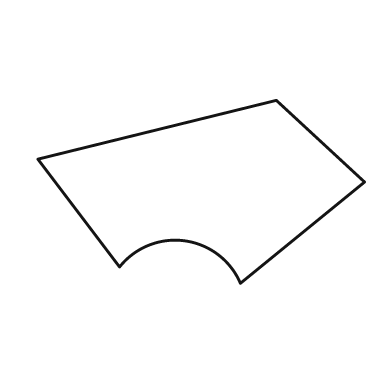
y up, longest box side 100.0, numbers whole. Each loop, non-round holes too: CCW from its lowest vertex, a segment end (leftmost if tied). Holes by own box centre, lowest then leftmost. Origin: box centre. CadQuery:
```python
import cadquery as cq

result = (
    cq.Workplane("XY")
    .moveTo(12.0, -28.0)
    .lineTo(50.0, 3.0)
    .lineTo(23.0, 28.0)
    .lineTo(-50.0, 10.0)
    .lineTo(-25.0, -23.0)
    .threePointArc((-5.0, -15.0), (12.0, -28.0))
    .close()
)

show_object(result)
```